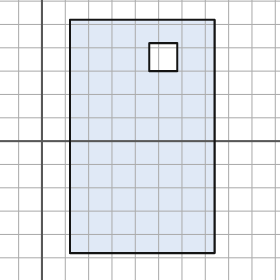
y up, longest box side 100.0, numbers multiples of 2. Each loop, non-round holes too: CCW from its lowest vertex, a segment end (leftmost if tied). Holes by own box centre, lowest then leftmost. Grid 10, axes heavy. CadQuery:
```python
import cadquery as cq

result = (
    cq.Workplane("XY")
    .moveTo(12.0, -48.0)
    .lineTo(74.0, -48.0)
    .lineTo(74.0, 52.0)
    .lineTo(12.0, 52.0)
    .close()
    .moveTo(46.0, 30.0)
    .lineTo(58.0, 30.0)
    .lineTo(58.0, 42.0)
    .lineTo(46.0, 42.0)
    .close()
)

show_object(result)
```